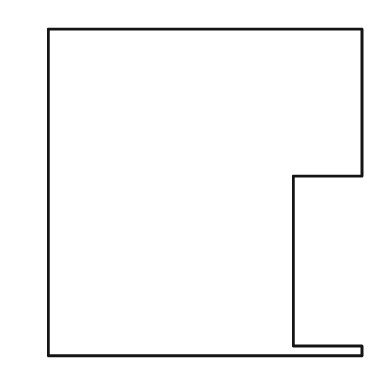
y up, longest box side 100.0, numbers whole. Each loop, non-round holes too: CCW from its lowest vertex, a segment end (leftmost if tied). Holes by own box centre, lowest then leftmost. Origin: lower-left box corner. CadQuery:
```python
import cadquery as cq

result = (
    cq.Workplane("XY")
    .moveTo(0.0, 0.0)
    .lineTo(96.0, 0.0)
    .lineTo(96.0, 3.0)
    .lineTo(75.0, 3.0)
    .lineTo(75.0, 55.0)
    .lineTo(96.0, 55.0)
    .lineTo(96.0, 100.0)
    .lineTo(0.0, 100.0)
    .close()
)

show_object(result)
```